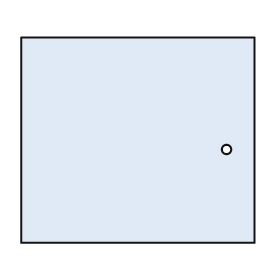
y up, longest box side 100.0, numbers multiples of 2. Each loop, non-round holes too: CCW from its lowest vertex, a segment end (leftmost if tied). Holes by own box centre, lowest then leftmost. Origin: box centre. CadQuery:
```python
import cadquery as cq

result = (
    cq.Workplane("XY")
    .moveTo(-50.0, -44.0)
    .lineTo(50.0, -44.0)
    .lineTo(50.0, 44.0)
    .lineTo(-50.0, 44.0)
    .close()
    .moveTo(38.0, -4.0)
    .circle(2.0)
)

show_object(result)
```